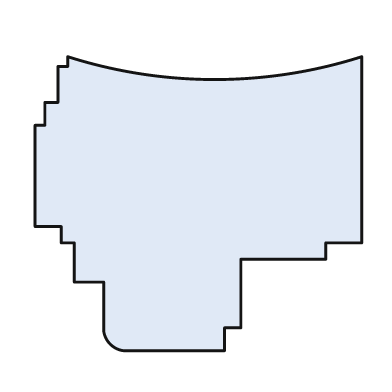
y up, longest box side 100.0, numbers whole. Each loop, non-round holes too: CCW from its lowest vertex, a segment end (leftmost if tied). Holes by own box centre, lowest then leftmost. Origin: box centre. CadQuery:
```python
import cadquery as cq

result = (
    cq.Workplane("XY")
    .moveTo(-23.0, -45.0)
    .lineTo(8.0, -45.0)
    .lineTo(8.0, -38.0)
    .lineTo(13.0, -38.0)
    .lineTo(13.0, -17.0)
    .lineTo(39.0, -17.0)
    .lineTo(39.0, -12.0)
    .lineTo(50.0, -12.0)
    .lineTo(50.0, 45.0)
    .threePointArc((5.0, 38.0), (-40.0, 45.0))
    .lineTo(-40.0, 42.0)
    .lineTo(-43.0, 42.0)
    .lineTo(-43.0, 31.0)
    .lineTo(-47.0, 31.0)
    .lineTo(-47.0, 24.0)
    .lineTo(-50.0, 24.0)
    .lineTo(-50.0, -7.0)
    .lineTo(-42.0, -7.0)
    .lineTo(-42.0, -12.0)
    .lineTo(-38.0, -12.0)
    .lineTo(-38.0, -24.0)
    .lineTo(-29.0, -24.0)
    .lineTo(-29.0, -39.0)
    .threePointArc((-27.0, -43.0), (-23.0, -45.0))
    .close()
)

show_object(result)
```